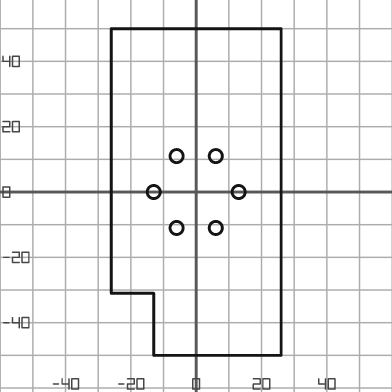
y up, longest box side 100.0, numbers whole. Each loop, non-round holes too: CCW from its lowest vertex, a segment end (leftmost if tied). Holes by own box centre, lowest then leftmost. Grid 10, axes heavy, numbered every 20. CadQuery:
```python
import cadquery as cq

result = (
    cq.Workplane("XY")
    .moveTo(-13.0, -50.0)
    .lineTo(26.0, -50.0)
    .lineTo(26.0, 50.0)
    .lineTo(-26.0, 50.0)
    .lineTo(-26.0, -31.0)
    .lineTo(-13.0, -31.0)
    .close()
    .moveTo(-6.0, -11.0)
    .circle(2.0)
    .moveTo(6.0, -11.0)
    .circle(2.0)
    .moveTo(-13.0, 0.0)
    .circle(2.0)
    .moveTo(13.0, 0.0)
    .circle(2.0)
    .moveTo(-6.0, 11.0)
    .circle(2.0)
    .moveTo(6.0, 11.0)
    .circle(2.0)
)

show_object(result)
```